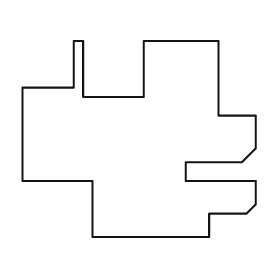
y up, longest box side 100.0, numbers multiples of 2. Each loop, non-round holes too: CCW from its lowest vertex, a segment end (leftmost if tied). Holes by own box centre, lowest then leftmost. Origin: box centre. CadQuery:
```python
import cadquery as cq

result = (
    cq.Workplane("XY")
    .moveTo(-20.0, -42.0)
    .lineTo(30.0, -42.0)
    .lineTo(30.0, -32.0)
    .lineTo(46.0, -32.0)
    .lineTo(50.0, -28.0)
    .lineTo(50.0, -18.0)
    .lineTo(20.0, -18.0)
    .lineTo(20.0, -10.0)
    .lineTo(44.0, -10.0)
    .lineTo(50.0, -4.0)
    .lineTo(50.0, 10.0)
    .lineTo(34.0, 10.0)
    .lineTo(34.0, 42.0)
    .lineTo(2.0, 42.0)
    .lineTo(2.0, 18.0)
    .lineTo(-24.0, 18.0)
    .lineTo(-24.0, 42.0)
    .lineTo(-28.0, 42.0)
    .lineTo(-28.0, 22.0)
    .lineTo(-50.0, 22.0)
    .lineTo(-50.0, -18.0)
    .lineTo(-20.0, -18.0)
    .close()
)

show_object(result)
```